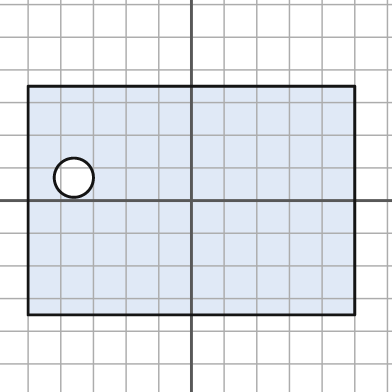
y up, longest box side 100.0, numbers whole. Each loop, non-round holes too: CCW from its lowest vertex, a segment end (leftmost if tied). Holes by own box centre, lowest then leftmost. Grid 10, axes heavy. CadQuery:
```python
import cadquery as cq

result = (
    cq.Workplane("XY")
    .moveTo(-50.0, -35.0)
    .lineTo(50.0, -35.0)
    .lineTo(50.0, 35.0)
    .lineTo(-50.0, 35.0)
    .close()
    .moveTo(-36.0, 7.0)
    .circle(6.0)
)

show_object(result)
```